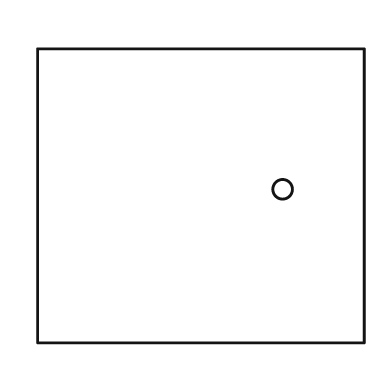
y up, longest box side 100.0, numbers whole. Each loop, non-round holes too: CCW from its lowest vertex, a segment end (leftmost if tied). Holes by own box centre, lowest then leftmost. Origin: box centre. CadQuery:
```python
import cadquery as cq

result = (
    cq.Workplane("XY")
    .moveTo(-50.0, -45.0)
    .lineTo(50.0, -45.0)
    .lineTo(50.0, 45.0)
    .lineTo(-50.0, 45.0)
    .close()
    .moveTo(25.0, 2.0)
    .circle(3.0)
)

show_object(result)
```